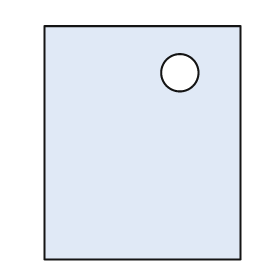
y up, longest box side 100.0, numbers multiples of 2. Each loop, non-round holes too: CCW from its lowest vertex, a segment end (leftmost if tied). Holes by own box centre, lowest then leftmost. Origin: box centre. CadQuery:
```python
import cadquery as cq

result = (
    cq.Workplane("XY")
    .moveTo(-42.0, -50.0)
    .lineTo(42.0, -50.0)
    .lineTo(42.0, 50.0)
    .lineTo(-42.0, 50.0)
    .close()
    .moveTo(16.0, 30.0)
    .circle(8.0)
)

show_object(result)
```